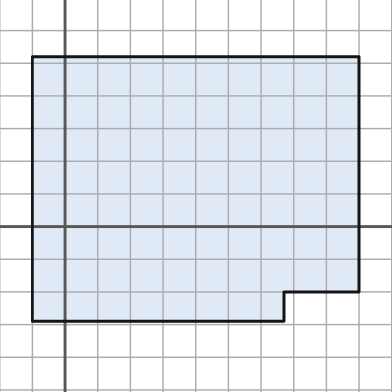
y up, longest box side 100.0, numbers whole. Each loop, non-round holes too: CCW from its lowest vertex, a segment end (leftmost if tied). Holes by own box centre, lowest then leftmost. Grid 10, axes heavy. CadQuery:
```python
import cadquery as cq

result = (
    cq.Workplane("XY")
    .moveTo(-10.0, -29.0)
    .lineTo(67.0, -29.0)
    .lineTo(67.0, -20.0)
    .lineTo(90.0, -20.0)
    .lineTo(90.0, 52.0)
    .lineTo(-10.0, 52.0)
    .close()
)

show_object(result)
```